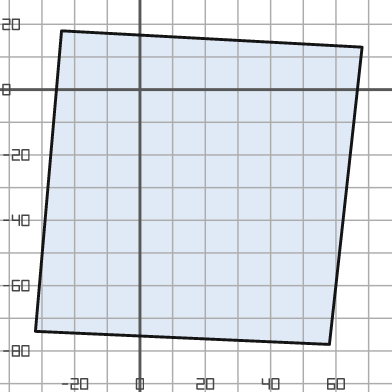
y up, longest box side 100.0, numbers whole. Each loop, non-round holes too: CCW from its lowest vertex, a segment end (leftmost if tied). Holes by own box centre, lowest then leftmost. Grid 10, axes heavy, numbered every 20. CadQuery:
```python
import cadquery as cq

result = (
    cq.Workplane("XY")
    .moveTo(58.0, -78.0)
    .lineTo(68.0, 13.0)
    .lineTo(-24.0, 18.0)
    .lineTo(-32.0, -74.0)
    .close()
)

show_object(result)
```